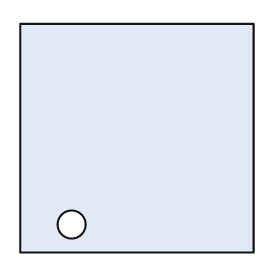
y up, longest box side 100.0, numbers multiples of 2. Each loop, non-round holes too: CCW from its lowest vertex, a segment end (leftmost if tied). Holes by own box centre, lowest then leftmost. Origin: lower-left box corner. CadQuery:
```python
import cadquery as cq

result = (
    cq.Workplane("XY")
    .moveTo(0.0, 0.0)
    .lineTo(100.0, 0.0)
    .lineTo(100.0, 98.0)
    .lineTo(0.0, 98.0)
    .close()
    .moveTo(22.0, 12.0)
    .circle(6.0)
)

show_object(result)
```